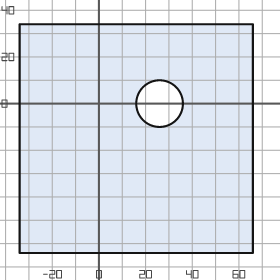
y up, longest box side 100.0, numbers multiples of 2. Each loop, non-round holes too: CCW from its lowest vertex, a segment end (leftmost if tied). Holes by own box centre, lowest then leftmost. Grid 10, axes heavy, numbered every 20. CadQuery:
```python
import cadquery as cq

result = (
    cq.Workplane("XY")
    .moveTo(-34.0, -64.0)
    .lineTo(66.0, -64.0)
    .lineTo(66.0, 34.0)
    .lineTo(-34.0, 34.0)
    .close()
    .moveTo(26.0, 0.0)
    .circle(10.0)
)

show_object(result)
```